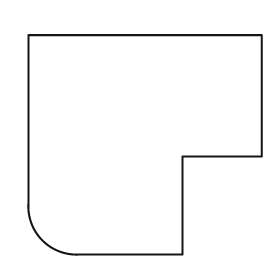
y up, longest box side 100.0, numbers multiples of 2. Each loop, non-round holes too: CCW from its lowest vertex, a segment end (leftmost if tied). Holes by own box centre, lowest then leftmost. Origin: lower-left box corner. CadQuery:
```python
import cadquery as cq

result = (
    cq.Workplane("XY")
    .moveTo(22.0, 0.0)
    .lineTo(66.0, 0.0)
    .lineTo(66.0, 42.0)
    .lineTo(100.0, 42.0)
    .lineTo(100.0, 94.0)
    .lineTo(0.0, 94.0)
    .lineTo(0.0, 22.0)
    .threePointArc((6.0, 6.0), (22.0, 0.0))
    .close()
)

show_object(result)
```